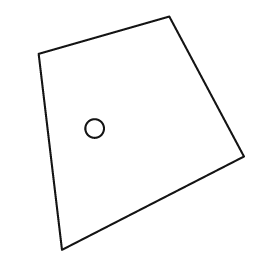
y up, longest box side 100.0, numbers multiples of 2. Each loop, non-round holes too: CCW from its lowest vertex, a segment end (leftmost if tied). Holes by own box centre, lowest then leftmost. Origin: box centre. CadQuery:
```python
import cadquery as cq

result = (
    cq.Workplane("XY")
    .moveTo(-34.0, -50.0)
    .lineTo(44.0, -10.0)
    .lineTo(12.0, 50.0)
    .lineTo(-44.0, 34.0)
    .close()
    .moveTo(-20.0, 2.0)
    .circle(4.0)
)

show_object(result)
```